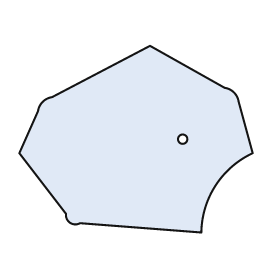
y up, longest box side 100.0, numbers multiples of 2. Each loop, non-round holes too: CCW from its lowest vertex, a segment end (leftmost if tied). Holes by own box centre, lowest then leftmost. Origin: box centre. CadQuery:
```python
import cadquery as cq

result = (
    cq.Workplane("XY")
    .moveTo(28.0, -40.0)
    .threePointArc((34.0, -20.0), (50.0, -6.0))
    .lineTo(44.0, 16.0)
    .threePointArc((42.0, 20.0), (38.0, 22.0))
    .lineTo(6.0, 40.0)
    .lineTo(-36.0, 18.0)
    .threePointArc((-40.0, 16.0), (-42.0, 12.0))
    .lineTo(-50.0, -6.0)
    .lineTo(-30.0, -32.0)
    .threePointArc((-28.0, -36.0), (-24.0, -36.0))
    .close()
    .moveTo(20.0, 0.0)
    .circle(2.0)
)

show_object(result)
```